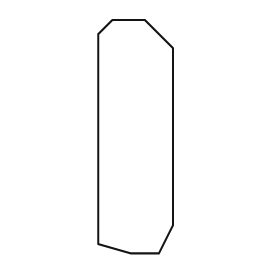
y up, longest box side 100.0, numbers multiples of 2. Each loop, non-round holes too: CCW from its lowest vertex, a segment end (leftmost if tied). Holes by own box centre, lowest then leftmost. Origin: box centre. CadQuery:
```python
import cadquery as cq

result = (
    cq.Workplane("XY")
    .moveTo(-2.0, -50.0)
    .lineTo(10.0, -50.0)
    .lineTo(16.0, -38.0)
    .lineTo(16.0, 38.0)
    .lineTo(4.0, 50.0)
    .lineTo(-10.0, 50.0)
    .lineTo(-16.0, 44.0)
    .lineTo(-16.0, -46.0)
    .close()
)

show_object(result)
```